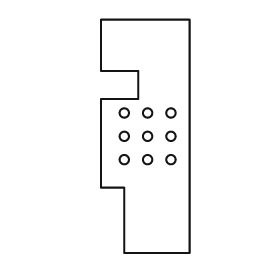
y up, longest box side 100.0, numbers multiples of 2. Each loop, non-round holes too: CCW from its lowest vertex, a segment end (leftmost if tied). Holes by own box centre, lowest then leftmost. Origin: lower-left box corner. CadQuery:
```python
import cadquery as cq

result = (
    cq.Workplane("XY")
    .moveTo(10.0, 0.0)
    .lineTo(38.0, 0.0)
    .lineTo(38.0, 100.0)
    .lineTo(0.0, 100.0)
    .lineTo(0.0, 78.0)
    .lineTo(16.0, 78.0)
    .lineTo(16.0, 66.0)
    .lineTo(0.0, 66.0)
    .lineTo(0.0, 28.0)
    .lineTo(10.0, 28.0)
    .close()
    .moveTo(10.0, 40.0)
    .circle(2.0)
    .moveTo(20.0, 40.0)
    .circle(2.0)
    .moveTo(30.0, 40.0)
    .circle(2.0)
    .moveTo(10.0, 50.0)
    .circle(2.0)
    .moveTo(20.0, 50.0)
    .circle(2.0)
    .moveTo(30.0, 50.0)
    .circle(2.0)
    .moveTo(10.0, 60.0)
    .circle(2.0)
    .moveTo(20.0, 60.0)
    .circle(2.0)
    .moveTo(30.0, 60.0)
    .circle(2.0)
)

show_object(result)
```